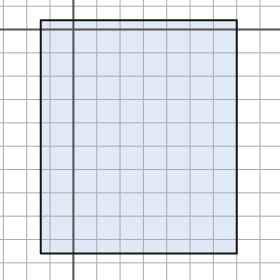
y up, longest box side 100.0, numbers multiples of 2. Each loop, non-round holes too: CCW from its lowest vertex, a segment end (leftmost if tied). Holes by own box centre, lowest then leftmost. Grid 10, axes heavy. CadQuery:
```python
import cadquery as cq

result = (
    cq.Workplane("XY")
    .moveTo(-14.0, -96.0)
    .lineTo(70.0, -96.0)
    .lineTo(70.0, 4.0)
    .lineTo(-14.0, 4.0)
    .close()
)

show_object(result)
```